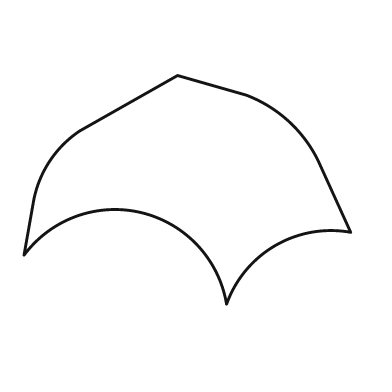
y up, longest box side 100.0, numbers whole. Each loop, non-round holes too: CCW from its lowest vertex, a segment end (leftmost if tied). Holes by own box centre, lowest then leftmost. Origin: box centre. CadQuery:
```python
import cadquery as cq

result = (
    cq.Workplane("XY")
    .moveTo(12.0, -35.0)
    .threePointArc((27.0, -17.0), (50.0, -13.0))
    .lineTo(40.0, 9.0)
    .threePointArc((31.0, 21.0), (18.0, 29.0))
    .lineTo(-3.0, 35.0)
    .lineTo(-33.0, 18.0)
    .threePointArc((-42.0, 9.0), (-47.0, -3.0))
    .lineTo(-50.0, -20.0)
    .threePointArc((-14.0, -7.0), (12.0, -35.0))
    .close()
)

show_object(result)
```